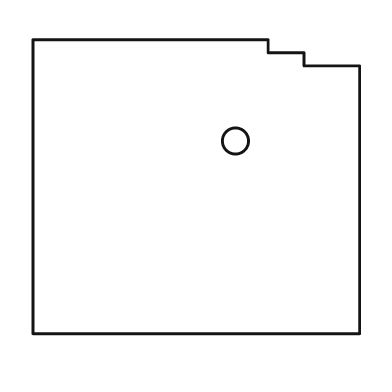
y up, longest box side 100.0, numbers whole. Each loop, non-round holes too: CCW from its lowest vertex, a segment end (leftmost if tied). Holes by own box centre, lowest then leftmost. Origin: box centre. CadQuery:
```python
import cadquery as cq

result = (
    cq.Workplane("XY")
    .moveTo(-50.0, -45.0)
    .lineTo(50.0, -45.0)
    .lineTo(50.0, 37.0)
    .lineTo(33.0, 37.0)
    .lineTo(33.0, 41.0)
    .lineTo(22.0, 41.0)
    .lineTo(22.0, 45.0)
    .lineTo(-50.0, 45.0)
    .close()
    .moveTo(12.0, 14.0)
    .circle(4.0)
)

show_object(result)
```